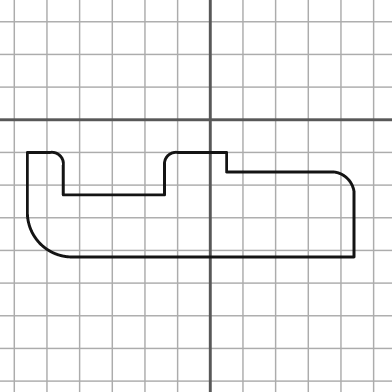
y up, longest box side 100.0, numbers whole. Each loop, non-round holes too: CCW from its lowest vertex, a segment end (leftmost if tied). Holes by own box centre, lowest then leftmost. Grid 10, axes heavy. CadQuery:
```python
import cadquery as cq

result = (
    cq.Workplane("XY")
    .moveTo(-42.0, -42.0)
    .lineTo(44.0, -42.0)
    .lineTo(44.0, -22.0)
    .threePointArc((42.0, -18.0), (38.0, -16.0))
    .lineTo(5.0, -16.0)
    .lineTo(5.0, -10.0)
    .lineTo(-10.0, -10.0)
    .threePointArc((-13.0, -11.0), (-14.0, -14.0))
    .lineTo(-14.0, -23.0)
    .lineTo(-45.0, -23.0)
    .lineTo(-45.0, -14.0)
    .threePointArc((-46.0, -11.0), (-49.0, -10.0))
    .lineTo(-56.0, -10.0)
    .lineTo(-56.0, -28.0)
    .threePointArc((-52.0, -38.0), (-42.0, -42.0))
    .close()
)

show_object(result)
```